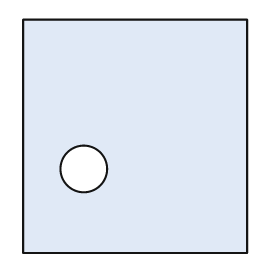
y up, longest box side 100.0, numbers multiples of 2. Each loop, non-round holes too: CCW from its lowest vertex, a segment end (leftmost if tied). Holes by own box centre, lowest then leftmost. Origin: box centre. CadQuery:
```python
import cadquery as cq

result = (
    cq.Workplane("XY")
    .moveTo(-48.0, -50.0)
    .lineTo(48.0, -50.0)
    .lineTo(48.0, 50.0)
    .lineTo(-48.0, 50.0)
    .close()
    .moveTo(-22.0, -14.0)
    .circle(10.0)
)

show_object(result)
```